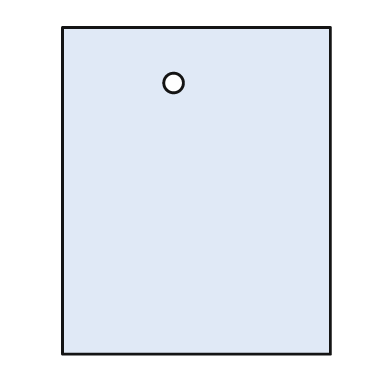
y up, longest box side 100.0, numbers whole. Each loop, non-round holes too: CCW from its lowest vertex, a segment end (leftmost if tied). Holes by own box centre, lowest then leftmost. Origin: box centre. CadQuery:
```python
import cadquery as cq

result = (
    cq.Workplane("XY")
    .moveTo(-41.0, -50.0)
    .lineTo(41.0, -50.0)
    .lineTo(41.0, 50.0)
    .lineTo(-41.0, 50.0)
    .close()
    .moveTo(-7.0, 33.0)
    .circle(3.0)
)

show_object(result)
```